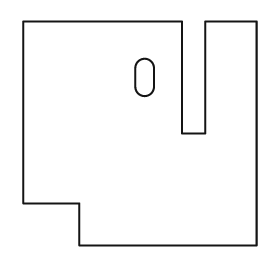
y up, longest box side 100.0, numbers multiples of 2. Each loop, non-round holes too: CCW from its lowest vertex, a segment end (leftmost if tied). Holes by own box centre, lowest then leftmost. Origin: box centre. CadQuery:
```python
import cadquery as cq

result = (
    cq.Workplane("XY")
    .moveTo(-26.0, -48.0)
    .lineTo(50.0, -48.0)
    .lineTo(50.0, 48.0)
    .lineTo(28.0, 48.0)
    .lineTo(28.0, 0.0)
    .lineTo(18.0, 0.0)
    .lineTo(18.0, 48.0)
    .lineTo(-50.0, 48.0)
    .lineTo(-50.0, -30.0)
    .lineTo(-26.0, -30.0)
    .close()
    .moveTo(-2.0, 20.0)
    .threePointArc((2.0, 16.0), (6.0, 20.0))
    .lineTo(6.0, 28.0)
    .threePointArc((2.0, 32.0), (-2.0, 28.0))
    .close()
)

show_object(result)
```